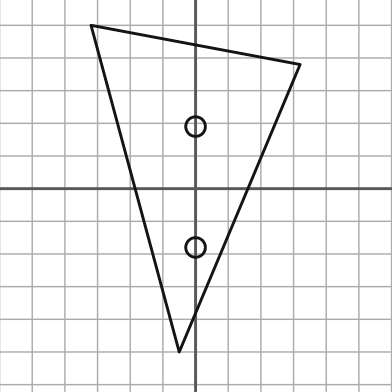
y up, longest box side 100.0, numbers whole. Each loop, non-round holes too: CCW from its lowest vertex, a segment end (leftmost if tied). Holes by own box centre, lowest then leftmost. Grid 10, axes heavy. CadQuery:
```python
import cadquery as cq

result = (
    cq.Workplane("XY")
    .moveTo(-5.0, -50.0)
    .lineTo(32.0, 38.0)
    .lineTo(-32.0, 50.0)
    .close()
    .moveTo(0.0, -18.0)
    .circle(3.0)
    .moveTo(0.0, 19.0)
    .circle(3.0)
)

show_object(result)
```